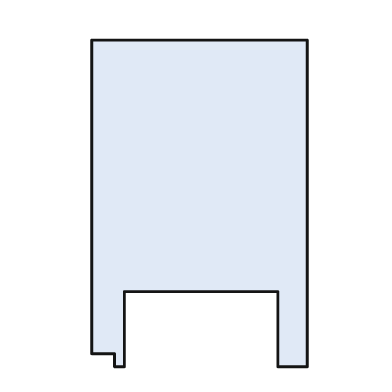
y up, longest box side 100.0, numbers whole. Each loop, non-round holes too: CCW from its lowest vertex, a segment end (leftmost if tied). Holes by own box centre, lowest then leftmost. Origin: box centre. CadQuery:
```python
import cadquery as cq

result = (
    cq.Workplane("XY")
    .moveTo(-26.0, -50.0)
    .lineTo(-23.0, -50.0)
    .lineTo(-23.0, -27.0)
    .lineTo(24.0, -27.0)
    .lineTo(24.0, -50.0)
    .lineTo(33.0, -50.0)
    .lineTo(33.0, 50.0)
    .lineTo(-33.0, 50.0)
    .lineTo(-33.0, -46.0)
    .lineTo(-26.0, -46.0)
    .close()
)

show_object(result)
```